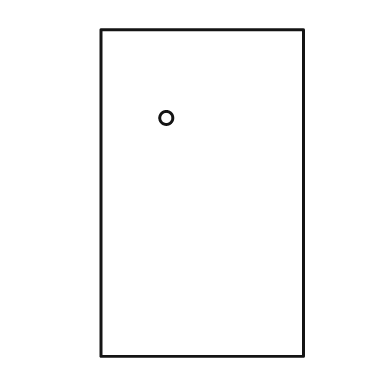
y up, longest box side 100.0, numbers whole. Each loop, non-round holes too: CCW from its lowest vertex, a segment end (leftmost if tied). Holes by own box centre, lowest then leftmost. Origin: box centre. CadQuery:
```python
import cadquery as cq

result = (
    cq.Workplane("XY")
    .moveTo(-31.0, -50.0)
    .lineTo(31.0, -50.0)
    .lineTo(31.0, 50.0)
    .lineTo(-31.0, 50.0)
    .close()
    .moveTo(-11.0, 23.0)
    .circle(2.0)
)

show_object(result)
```